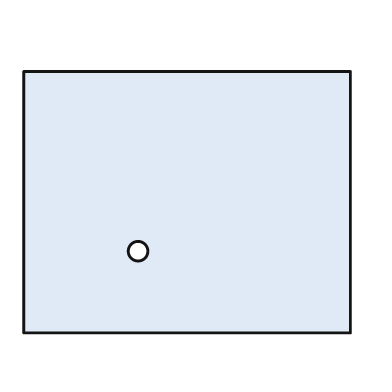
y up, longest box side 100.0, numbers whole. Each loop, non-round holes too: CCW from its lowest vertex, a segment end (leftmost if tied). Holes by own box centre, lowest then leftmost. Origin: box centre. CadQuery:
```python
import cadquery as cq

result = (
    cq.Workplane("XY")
    .moveTo(-50.0, -40.0)
    .lineTo(50.0, -40.0)
    .lineTo(50.0, 40.0)
    .lineTo(-50.0, 40.0)
    .close()
    .moveTo(-15.0, -15.0)
    .circle(3.0)
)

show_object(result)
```